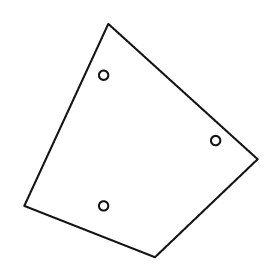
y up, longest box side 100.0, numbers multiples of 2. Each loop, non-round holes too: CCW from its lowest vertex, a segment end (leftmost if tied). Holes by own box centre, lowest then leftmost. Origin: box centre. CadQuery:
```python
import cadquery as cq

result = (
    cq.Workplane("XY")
    .moveTo(6.0, -50.0)
    .lineTo(50.0, -8.0)
    .lineTo(-14.0, 50.0)
    .lineTo(-50.0, -28.0)
    .close()
    .moveTo(-16.0, -28.0)
    .circle(2.0)
    .moveTo(32.0, 0.0)
    .circle(2.0)
    .moveTo(-16.0, 28.0)
    .circle(2.0)
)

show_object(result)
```